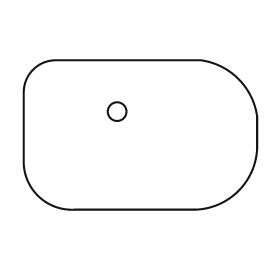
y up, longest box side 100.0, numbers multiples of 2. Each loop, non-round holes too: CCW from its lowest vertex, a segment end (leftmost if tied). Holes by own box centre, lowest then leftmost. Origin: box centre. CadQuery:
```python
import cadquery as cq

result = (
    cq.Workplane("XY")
    .moveTo(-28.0, -32.0)
    .lineTo(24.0, -32.0)
    .threePointArc((42.0, -24.0), (50.0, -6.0))
    .lineTo(50.0, 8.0)
    .threePointArc((42.0, 24.0), (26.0, 32.0))
    .lineTo(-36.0, 32.0)
    .threePointArc((-46.0, 28.0), (-50.0, 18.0))
    .lineTo(-50.0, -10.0)
    .threePointArc((-44.0, -26.0), (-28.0, -32.0))
    .close()
    .moveTo(-10.0, 10.0)
    .circle(4.0)
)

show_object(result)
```